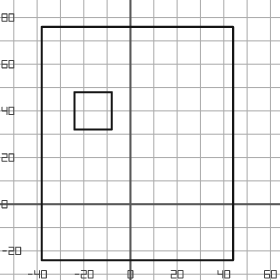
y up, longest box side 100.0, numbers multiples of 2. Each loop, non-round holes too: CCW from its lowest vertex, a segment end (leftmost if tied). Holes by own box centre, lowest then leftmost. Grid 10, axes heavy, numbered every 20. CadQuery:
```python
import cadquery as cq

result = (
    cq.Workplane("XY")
    .moveTo(-38.0, -24.0)
    .lineTo(44.0, -24.0)
    .lineTo(44.0, 76.0)
    .lineTo(-38.0, 76.0)
    .close()
    .moveTo(-24.0, 32.0)
    .lineTo(-8.0, 32.0)
    .lineTo(-8.0, 48.0)
    .lineTo(-24.0, 48.0)
    .close()
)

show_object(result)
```